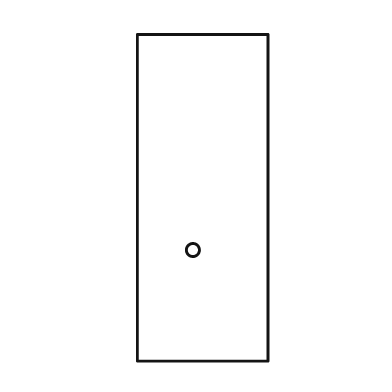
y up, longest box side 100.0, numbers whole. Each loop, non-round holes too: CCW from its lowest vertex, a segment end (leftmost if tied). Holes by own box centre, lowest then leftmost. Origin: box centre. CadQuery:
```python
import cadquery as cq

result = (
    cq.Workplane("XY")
    .moveTo(-20.0, -50.0)
    .lineTo(20.0, -50.0)
    .lineTo(20.0, 50.0)
    .lineTo(-20.0, 50.0)
    .close()
    .moveTo(-3.0, -16.0)
    .circle(2.0)
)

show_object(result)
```